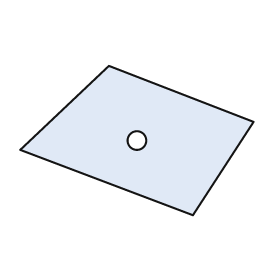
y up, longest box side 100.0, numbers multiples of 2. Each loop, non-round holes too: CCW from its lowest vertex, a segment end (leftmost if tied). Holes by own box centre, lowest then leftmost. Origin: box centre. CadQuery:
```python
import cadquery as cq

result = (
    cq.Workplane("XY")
    .moveTo(24.0, -32.0)
    .lineTo(50.0, 8.0)
    .lineTo(-12.0, 32.0)
    .lineTo(-50.0, -4.0)
    .close()
    .moveTo(0.0, 0.0)
    .circle(4.0)
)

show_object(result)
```